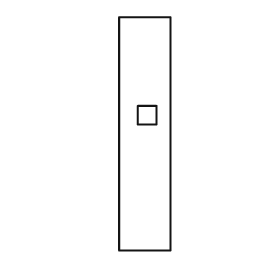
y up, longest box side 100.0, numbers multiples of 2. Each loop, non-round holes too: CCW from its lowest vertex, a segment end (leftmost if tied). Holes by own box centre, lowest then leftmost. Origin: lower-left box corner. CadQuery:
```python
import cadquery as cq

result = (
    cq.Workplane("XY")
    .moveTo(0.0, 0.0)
    .lineTo(22.0, 0.0)
    .lineTo(22.0, 100.0)
    .lineTo(0.0, 100.0)
    .close()
    .moveTo(8.0, 54.0)
    .lineTo(16.0, 54.0)
    .lineTo(16.0, 62.0)
    .lineTo(8.0, 62.0)
    .close()
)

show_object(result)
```